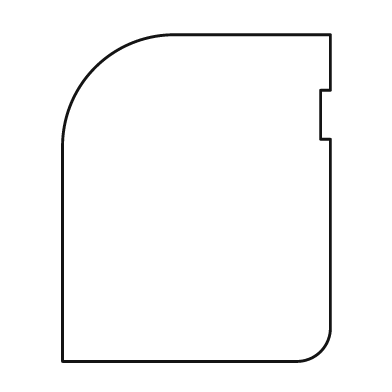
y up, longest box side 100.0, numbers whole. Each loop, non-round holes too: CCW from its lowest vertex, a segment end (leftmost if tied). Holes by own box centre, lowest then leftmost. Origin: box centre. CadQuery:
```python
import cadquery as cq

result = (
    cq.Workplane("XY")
    .moveTo(-41.0, -50.0)
    .lineTo(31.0, -50.0)
    .threePointArc((38.0, -47.0), (41.0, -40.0))
    .lineTo(41.0, 18.0)
    .lineTo(38.0, 18.0)
    .lineTo(38.0, 33.0)
    .lineTo(41.0, 33.0)
    .lineTo(41.0, 50.0)
    .lineTo(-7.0, 50.0)
    .threePointArc((-31.0, 40.0), (-41.0, 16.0))
    .close()
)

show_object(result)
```